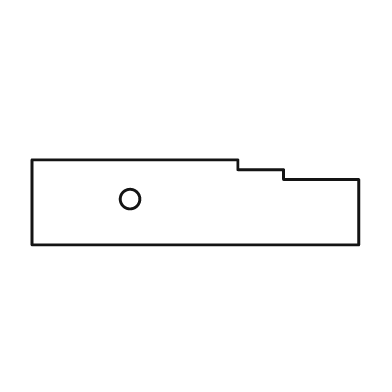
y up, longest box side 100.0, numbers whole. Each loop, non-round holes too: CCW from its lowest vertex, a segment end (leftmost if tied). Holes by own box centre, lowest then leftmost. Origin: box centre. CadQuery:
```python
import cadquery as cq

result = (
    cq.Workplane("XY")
    .moveTo(-50.0, -13.0)
    .lineTo(50.0, -13.0)
    .lineTo(50.0, 7.0)
    .lineTo(27.0, 7.0)
    .lineTo(27.0, 10.0)
    .lineTo(13.0, 10.0)
    .lineTo(13.0, 13.0)
    .lineTo(-50.0, 13.0)
    .close()
    .moveTo(-20.0, 1.0)
    .circle(3.0)
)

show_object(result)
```